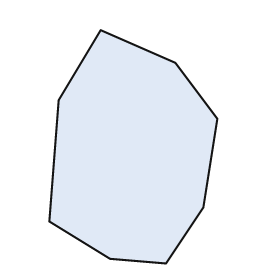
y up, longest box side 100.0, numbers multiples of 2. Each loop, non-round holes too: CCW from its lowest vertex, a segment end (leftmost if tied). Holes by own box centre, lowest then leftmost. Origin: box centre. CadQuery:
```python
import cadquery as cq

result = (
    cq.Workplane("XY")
    .moveTo(14.0, -50.0)
    .lineTo(30.0, -26.0)
    .lineTo(36.0, 12.0)
    .lineTo(18.0, 36.0)
    .lineTo(-14.0, 50.0)
    .lineTo(-32.0, 20.0)
    .lineTo(-36.0, -32.0)
    .lineTo(-10.0, -48.0)
    .close()
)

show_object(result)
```